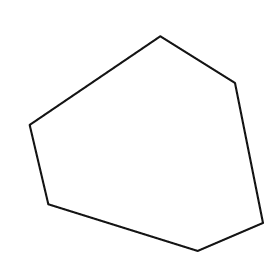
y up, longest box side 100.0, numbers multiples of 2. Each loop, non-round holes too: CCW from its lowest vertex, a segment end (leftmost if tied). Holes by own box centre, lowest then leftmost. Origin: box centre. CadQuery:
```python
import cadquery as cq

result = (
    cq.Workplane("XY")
    .moveTo(22.0, -46.0)
    .lineTo(50.0, -34.0)
    .lineTo(38.0, 26.0)
    .lineTo(6.0, 46.0)
    .lineTo(-50.0, 8.0)
    .lineTo(-42.0, -26.0)
    .close()
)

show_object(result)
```